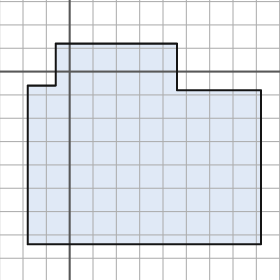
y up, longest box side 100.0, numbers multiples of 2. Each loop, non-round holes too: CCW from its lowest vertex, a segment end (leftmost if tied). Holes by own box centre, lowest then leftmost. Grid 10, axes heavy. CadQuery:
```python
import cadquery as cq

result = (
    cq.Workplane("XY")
    .moveTo(-18.0, -74.0)
    .lineTo(82.0, -74.0)
    .lineTo(82.0, -8.0)
    .lineTo(46.0, -8.0)
    .lineTo(46.0, 12.0)
    .lineTo(-6.0, 12.0)
    .lineTo(-6.0, -6.0)
    .lineTo(-18.0, -6.0)
    .close()
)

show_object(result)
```